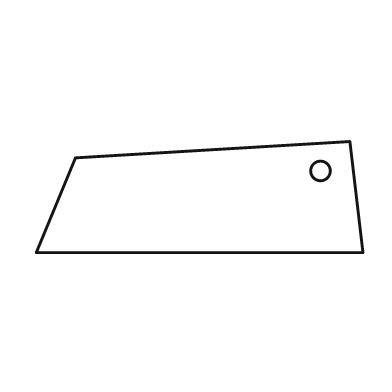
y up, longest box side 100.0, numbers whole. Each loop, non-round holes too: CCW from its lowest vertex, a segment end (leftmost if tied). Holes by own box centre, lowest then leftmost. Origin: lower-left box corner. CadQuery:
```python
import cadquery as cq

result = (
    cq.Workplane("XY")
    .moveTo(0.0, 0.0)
    .lineTo(100.0, 0.0)
    .lineTo(96.0, 34.0)
    .lineTo(12.0, 29.0)
    .close()
    .moveTo(87.0, 25.0)
    .circle(3.0)
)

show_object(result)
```